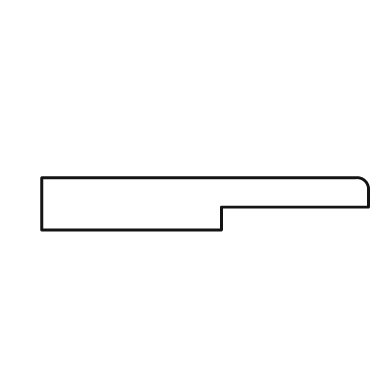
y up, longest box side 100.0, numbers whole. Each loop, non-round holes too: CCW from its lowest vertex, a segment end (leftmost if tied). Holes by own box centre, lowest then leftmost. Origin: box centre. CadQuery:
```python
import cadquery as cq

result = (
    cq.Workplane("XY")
    .moveTo(-50.0, -8.0)
    .lineTo(5.0, -8.0)
    .lineTo(5.0, -1.0)
    .lineTo(50.0, -1.0)
    .lineTo(50.0, 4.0)
    .threePointArc((49.0, 7.0), (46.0, 8.0))
    .lineTo(-50.0, 8.0)
    .close()
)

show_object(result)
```